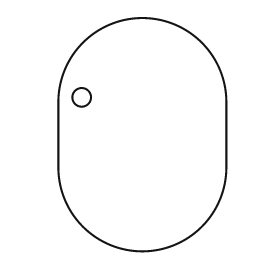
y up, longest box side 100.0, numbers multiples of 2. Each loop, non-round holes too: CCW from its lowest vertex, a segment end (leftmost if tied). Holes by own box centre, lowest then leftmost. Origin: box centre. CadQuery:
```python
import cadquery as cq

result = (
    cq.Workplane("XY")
    .moveTo(-36.0, -14.0)
    .threePointArc((0.0, -50.0), (36.0, -14.0))
    .lineTo(36.0, 14.0)
    .threePointArc((0.0, 50.0), (-36.0, 14.0))
    .close()
    .moveTo(-26.0, 16.0)
    .circle(4.0)
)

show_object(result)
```